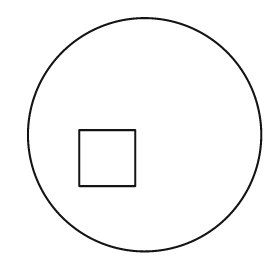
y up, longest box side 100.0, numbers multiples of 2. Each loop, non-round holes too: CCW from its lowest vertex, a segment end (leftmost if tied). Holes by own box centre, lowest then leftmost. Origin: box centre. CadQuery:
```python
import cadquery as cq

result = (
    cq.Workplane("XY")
    .moveTo(0.0, 0.0)
    .circle(50.0)
    .moveTo(-28.0, -22.0)
    .lineTo(-4.0, -22.0)
    .lineTo(-4.0, 2.0)
    .lineTo(-28.0, 2.0)
    .close()
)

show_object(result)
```